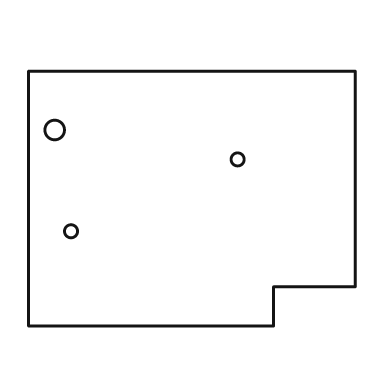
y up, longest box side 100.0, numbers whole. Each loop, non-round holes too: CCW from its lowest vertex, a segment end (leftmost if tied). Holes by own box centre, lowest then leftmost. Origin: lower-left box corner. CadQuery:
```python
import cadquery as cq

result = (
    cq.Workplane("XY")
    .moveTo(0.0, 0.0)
    .lineTo(75.0, 0.0)
    .lineTo(75.0, 12.0)
    .lineTo(100.0, 12.0)
    .lineTo(100.0, 78.0)
    .lineTo(0.0, 78.0)
    .close()
    .moveTo(13.0, 29.0)
    .circle(2.0)
    .moveTo(64.0, 51.0)
    .circle(2.0)
    .moveTo(8.0, 60.0)
    .circle(3.0)
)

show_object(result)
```